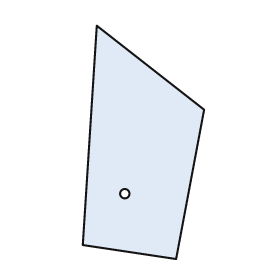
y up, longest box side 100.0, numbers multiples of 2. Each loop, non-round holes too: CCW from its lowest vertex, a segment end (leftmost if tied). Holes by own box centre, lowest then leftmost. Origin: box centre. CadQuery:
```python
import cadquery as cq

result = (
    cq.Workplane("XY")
    .moveTo(14.0, -50.0)
    .lineTo(26.0, 14.0)
    .lineTo(-20.0, 50.0)
    .lineTo(-26.0, -44.0)
    .close()
    .moveTo(-8.0, -22.0)
    .circle(2.0)
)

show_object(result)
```